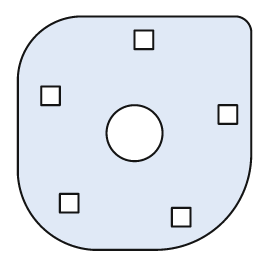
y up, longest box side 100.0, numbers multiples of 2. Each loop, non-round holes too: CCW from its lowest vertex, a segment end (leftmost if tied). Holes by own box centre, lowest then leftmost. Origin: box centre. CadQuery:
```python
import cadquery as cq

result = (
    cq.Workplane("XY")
    .moveTo(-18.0, -50.0)
    .lineTo(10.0, -50.0)
    .threePointArc((38.0, -38.0), (50.0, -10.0))
    .lineTo(50.0, 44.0)
    .threePointArc((48.0, 48.0), (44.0, 50.0))
    .lineTo(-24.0, 50.0)
    .threePointArc((-42.0, 42.0), (-50.0, 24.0))
    .lineTo(-50.0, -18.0)
    .threePointArc((-40.0, -40.0), (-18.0, -50.0))
    .close()
    .moveTo(16.0, -40.0)
    .lineTo(24.0, -40.0)
    .lineTo(24.0, -32.0)
    .lineTo(16.0, -32.0)
    .close()
    .moveTo(-32.0, -34.0)
    .lineTo(-24.0, -34.0)
    .lineTo(-24.0, -26.0)
    .lineTo(-32.0, -26.0)
    .close()
    .moveTo(0.0, 0.0)
    .circle(12.0)
    .moveTo(36.0, 4.0)
    .lineTo(44.0, 4.0)
    .lineTo(44.0, 12.0)
    .lineTo(36.0, 12.0)
    .close()
    .moveTo(-40.0, 12.0)
    .lineTo(-32.0, 12.0)
    .lineTo(-32.0, 20.0)
    .lineTo(-40.0, 20.0)
    .close()
    .moveTo(0.0, 36.0)
    .lineTo(8.0, 36.0)
    .lineTo(8.0, 44.0)
    .lineTo(0.0, 44.0)
    .close()
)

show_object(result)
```